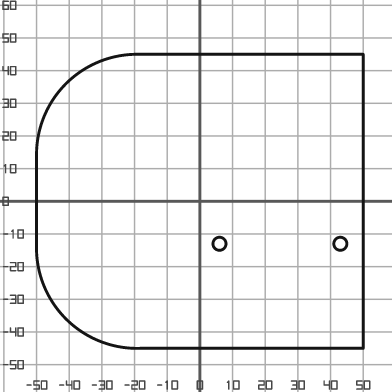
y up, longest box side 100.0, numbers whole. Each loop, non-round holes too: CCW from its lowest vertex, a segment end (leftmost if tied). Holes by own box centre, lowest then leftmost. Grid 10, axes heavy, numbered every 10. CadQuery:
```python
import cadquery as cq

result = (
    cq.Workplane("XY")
    .moveTo(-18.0, -45.0)
    .lineTo(50.0, -45.0)
    .lineTo(50.0, 45.0)
    .lineTo(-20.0, 45.0)
    .threePointArc((-41.0, 36.0), (-50.0, 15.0))
    .lineTo(-50.0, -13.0)
    .threePointArc((-41.0, -36.0), (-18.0, -45.0))
    .close()
    .moveTo(6.0, -13.0)
    .circle(2.0)
    .moveTo(43.0, -13.0)
    .circle(2.0)
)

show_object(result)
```